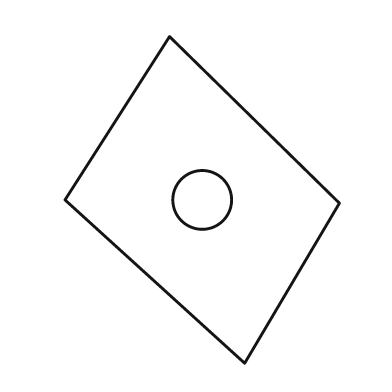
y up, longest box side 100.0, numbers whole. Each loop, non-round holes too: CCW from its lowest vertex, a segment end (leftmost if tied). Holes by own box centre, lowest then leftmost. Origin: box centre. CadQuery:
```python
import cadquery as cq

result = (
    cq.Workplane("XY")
    .moveTo(13.0, -50.0)
    .lineTo(42.0, -1.0)
    .lineTo(-10.0, 50.0)
    .lineTo(-42.0, 0.0)
    .close()
    .moveTo(0.0, 0.0)
    .circle(9.0)
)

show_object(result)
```